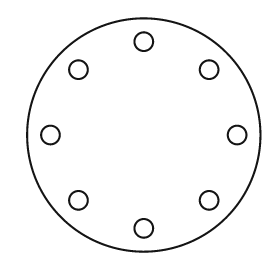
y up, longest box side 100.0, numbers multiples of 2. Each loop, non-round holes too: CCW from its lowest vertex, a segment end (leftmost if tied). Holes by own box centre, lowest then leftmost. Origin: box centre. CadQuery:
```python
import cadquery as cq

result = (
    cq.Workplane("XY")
    .moveTo(0.0, 0.0)
    .circle(50.0)
    .moveTo(0.0, -40.0)
    .circle(4.0)
    .moveTo(-28.0, -28.0)
    .circle(4.0)
    .moveTo(28.0, -28.0)
    .circle(4.0)
    .moveTo(-40.0, 0.0)
    .circle(4.0)
    .moveTo(40.0, 0.0)
    .circle(4.0)
    .moveTo(-28.0, 28.0)
    .circle(4.0)
    .moveTo(28.0, 28.0)
    .circle(4.0)
    .moveTo(0.0, 40.0)
    .circle(4.0)
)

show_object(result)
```